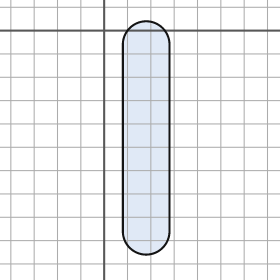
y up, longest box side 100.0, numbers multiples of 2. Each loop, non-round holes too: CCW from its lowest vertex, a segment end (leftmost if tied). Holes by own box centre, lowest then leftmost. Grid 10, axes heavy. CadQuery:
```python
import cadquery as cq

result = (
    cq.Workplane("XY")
    .moveTo(8.0, -86.0)
    .threePointArc((18.0, -96.0), (28.0, -86.0))
    .lineTo(28.0, -6.0)
    .threePointArc((18.0, 4.0), (8.0, -6.0))
    .close()
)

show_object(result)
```